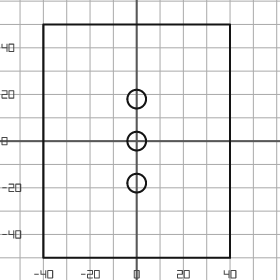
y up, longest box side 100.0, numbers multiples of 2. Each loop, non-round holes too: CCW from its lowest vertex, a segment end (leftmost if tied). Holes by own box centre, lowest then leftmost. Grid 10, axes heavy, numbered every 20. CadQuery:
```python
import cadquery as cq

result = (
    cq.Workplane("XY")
    .moveTo(-40.0, -50.0)
    .lineTo(40.0, -50.0)
    .lineTo(40.0, 50.0)
    .lineTo(-40.0, 50.0)
    .close()
    .moveTo(0.0, -18.0)
    .circle(4.0)
    .moveTo(0.0, 0.0)
    .circle(4.0)
    .moveTo(0.0, 18.0)
    .circle(4.0)
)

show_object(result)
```